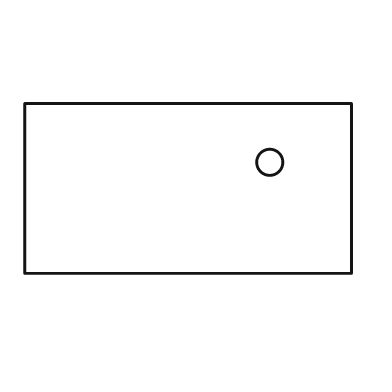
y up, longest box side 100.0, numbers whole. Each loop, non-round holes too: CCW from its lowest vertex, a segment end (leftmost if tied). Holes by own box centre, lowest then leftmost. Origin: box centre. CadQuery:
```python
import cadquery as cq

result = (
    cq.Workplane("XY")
    .moveTo(-50.0, -26.0)
    .lineTo(50.0, -26.0)
    .lineTo(50.0, 26.0)
    .lineTo(-50.0, 26.0)
    .close()
    .moveTo(25.0, 8.0)
    .circle(4.0)
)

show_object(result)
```